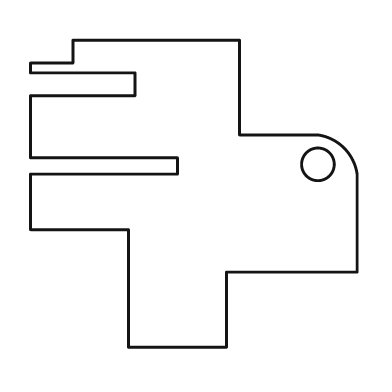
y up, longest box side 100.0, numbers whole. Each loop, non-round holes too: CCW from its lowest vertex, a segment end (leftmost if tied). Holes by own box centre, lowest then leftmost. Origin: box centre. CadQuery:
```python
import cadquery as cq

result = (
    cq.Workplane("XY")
    .moveTo(-20.0, -47.0)
    .lineTo(10.0, -47.0)
    .lineTo(10.0, -24.0)
    .lineTo(50.0, -24.0)
    .lineTo(50.0, 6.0)
    .threePointArc((46.0, 14.0), (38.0, 18.0))
    .lineTo(14.0, 18.0)
    .lineTo(14.0, 47.0)
    .lineTo(-37.0, 47.0)
    .lineTo(-37.0, 40.0)
    .lineTo(-50.0, 40.0)
    .lineTo(-50.0, 37.0)
    .lineTo(-18.0, 37.0)
    .lineTo(-18.0, 30.0)
    .lineTo(-50.0, 30.0)
    .lineTo(-50.0, 11.0)
    .lineTo(-5.0, 11.0)
    .lineTo(-5.0, 6.0)
    .lineTo(-50.0, 6.0)
    .lineTo(-50.0, -11.0)
    .lineTo(-20.0, -11.0)
    .close()
    .moveTo(38.0, 9.0)
    .circle(5.0)
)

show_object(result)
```